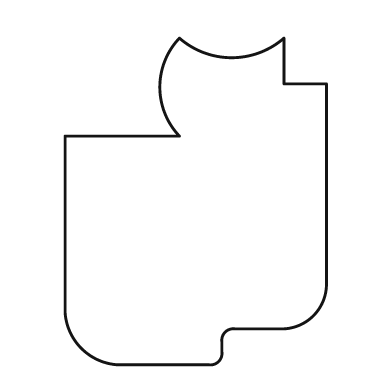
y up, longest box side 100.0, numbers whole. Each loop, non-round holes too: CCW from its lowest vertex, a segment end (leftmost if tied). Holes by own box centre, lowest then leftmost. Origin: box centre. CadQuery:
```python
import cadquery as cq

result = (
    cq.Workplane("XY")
    .moveTo(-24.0, -50.0)
    .lineTo(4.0, -50.0)
    .threePointArc((7.0, -49.0), (8.0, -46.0))
    .lineTo(8.0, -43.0)
    .threePointArc((9.0, -40.0), (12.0, -39.0))
    .lineTo(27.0, -39.0)
    .threePointArc((36.0, -35.0), (40.0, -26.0))
    .lineTo(40.0, 36.0)
    .lineTo(27.0, 36.0)
    .lineTo(27.0, 50.0)
    .threePointArc((11.0, 44.0), (-5.0, 50.0))
    .threePointArc((-11.0, 35.0), (-5.0, 20.0))
    .lineTo(-40.0, 20.0)
    .lineTo(-40.0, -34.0)
    .threePointArc((-35.0, -45.0), (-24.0, -50.0))
    .close()
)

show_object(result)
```